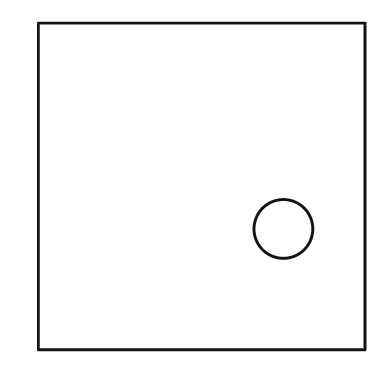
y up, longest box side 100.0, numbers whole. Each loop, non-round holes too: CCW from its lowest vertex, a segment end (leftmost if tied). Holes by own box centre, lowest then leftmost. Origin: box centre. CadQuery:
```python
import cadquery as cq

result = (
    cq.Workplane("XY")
    .moveTo(-50.0, -50.0)
    .lineTo(50.0, -50.0)
    .lineTo(50.0, 50.0)
    .lineTo(-50.0, 50.0)
    .close()
    .moveTo(25.0, -13.0)
    .circle(9.0)
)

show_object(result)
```